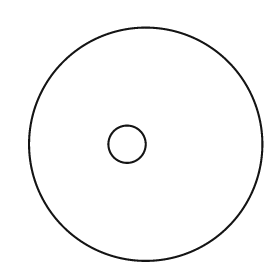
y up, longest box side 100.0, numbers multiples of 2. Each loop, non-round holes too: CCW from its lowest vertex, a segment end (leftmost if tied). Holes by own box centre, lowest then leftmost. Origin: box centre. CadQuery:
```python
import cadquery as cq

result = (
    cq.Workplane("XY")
    .moveTo(0.0, 0.0)
    .circle(50.0)
    .moveTo(-8.0, 0.0)
    .circle(8.0)
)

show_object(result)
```